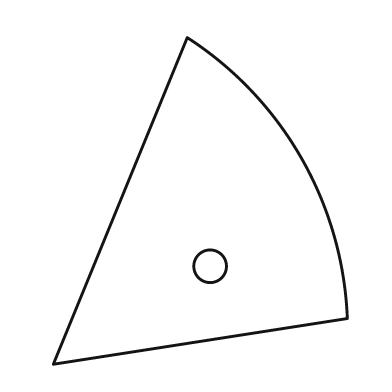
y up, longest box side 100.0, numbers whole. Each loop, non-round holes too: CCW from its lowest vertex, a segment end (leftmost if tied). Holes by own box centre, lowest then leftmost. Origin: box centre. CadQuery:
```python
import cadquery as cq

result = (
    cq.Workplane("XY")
    .moveTo(-45.0, -50.0)
    .lineTo(45.0, -36.0)
    .threePointArc((31.0, 13.0), (-4.0, 50.0))
    .close()
    .moveTo(3.0, -20.0)
    .circle(5.0)
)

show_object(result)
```